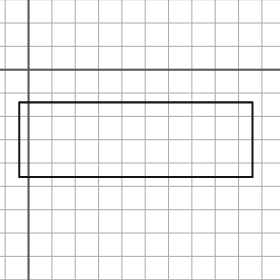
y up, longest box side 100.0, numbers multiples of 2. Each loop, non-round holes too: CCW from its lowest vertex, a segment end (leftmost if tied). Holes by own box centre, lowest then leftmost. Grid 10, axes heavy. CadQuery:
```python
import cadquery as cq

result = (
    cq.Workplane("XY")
    .moveTo(-4.0, -46.0)
    .lineTo(96.0, -46.0)
    .lineTo(96.0, -14.0)
    .lineTo(-4.0, -14.0)
    .close()
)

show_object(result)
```